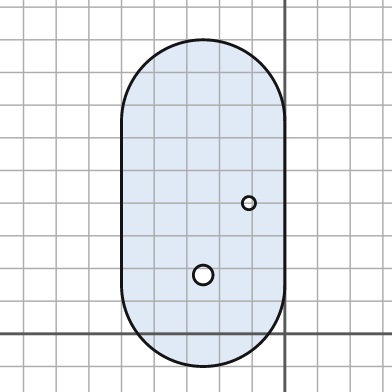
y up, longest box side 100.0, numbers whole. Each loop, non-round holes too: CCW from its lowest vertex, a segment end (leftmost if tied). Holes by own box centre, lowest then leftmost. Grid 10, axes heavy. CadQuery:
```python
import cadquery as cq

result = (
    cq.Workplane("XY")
    .moveTo(-50.0, 15.0)
    .threePointArc((-25.0, -10.0), (0.0, 15.0))
    .lineTo(0.0, 65.0)
    .threePointArc((-25.0, 90.0), (-50.0, 65.0))
    .close()
    .moveTo(-25.0, 18.0)
    .circle(3.0)
    .moveTo(-11.0, 40.0)
    .circle(2.0)
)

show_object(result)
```